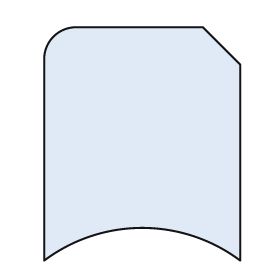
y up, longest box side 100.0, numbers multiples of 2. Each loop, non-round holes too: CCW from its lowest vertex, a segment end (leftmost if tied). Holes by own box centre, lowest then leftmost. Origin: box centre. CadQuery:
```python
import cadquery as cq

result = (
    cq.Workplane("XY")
    .moveTo(-42.0, -50.0)
    .threePointArc((0.0, -36.0), (42.0, -50.0))
    .lineTo(42.0, 34.0)
    .lineTo(26.0, 50.0)
    .lineTo(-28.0, 50.0)
    .threePointArc((-38.0, 46.0), (-42.0, 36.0))
    .close()
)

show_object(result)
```